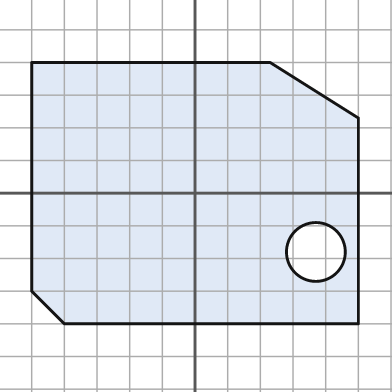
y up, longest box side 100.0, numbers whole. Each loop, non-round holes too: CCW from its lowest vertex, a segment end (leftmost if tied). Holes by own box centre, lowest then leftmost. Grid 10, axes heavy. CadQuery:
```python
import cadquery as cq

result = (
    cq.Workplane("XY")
    .moveTo(-40.0, -40.0)
    .lineTo(50.0, -40.0)
    .lineTo(50.0, 23.0)
    .lineTo(23.0, 40.0)
    .lineTo(-50.0, 40.0)
    .lineTo(-50.0, -30.0)
    .close()
    .moveTo(37.0, -18.0)
    .circle(9.0)
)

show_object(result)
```